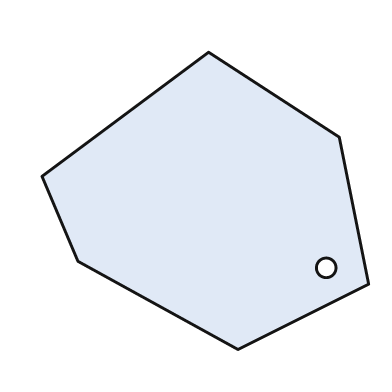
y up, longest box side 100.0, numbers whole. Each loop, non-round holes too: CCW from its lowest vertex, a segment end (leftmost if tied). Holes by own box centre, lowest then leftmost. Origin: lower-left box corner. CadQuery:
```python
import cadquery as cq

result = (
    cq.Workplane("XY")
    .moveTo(60.0, 0.0)
    .lineTo(100.0, 20.0)
    .lineTo(91.0, 65.0)
    .lineTo(51.0, 91.0)
    .lineTo(0.0, 53.0)
    .lineTo(11.0, 27.0)
    .close()
    .moveTo(87.0, 25.0)
    .circle(3.0)
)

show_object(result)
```